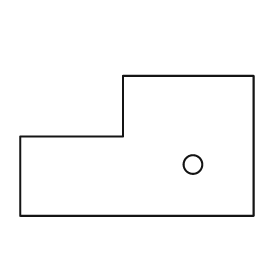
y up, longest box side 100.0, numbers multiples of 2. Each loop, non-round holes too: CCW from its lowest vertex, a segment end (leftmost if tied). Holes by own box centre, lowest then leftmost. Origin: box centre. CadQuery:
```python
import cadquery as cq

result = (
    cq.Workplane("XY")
    .moveTo(-50.0, -30.0)
    .lineTo(50.0, -30.0)
    .lineTo(50.0, 30.0)
    .lineTo(-6.0, 30.0)
    .lineTo(-6.0, 4.0)
    .lineTo(-50.0, 4.0)
    .close()
    .moveTo(24.0, -8.0)
    .circle(4.0)
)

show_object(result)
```